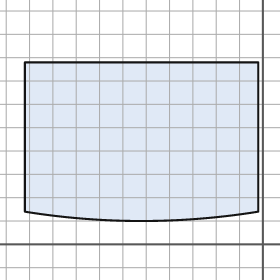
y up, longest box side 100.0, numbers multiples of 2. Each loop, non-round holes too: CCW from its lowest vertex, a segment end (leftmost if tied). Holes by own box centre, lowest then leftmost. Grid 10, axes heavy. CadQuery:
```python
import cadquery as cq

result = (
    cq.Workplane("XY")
    .moveTo(-102.0, 14.0)
    .threePointArc((-52.0, 10.0), (-2.0, 14.0))
    .lineTo(-2.0, 78.0)
    .lineTo(-102.0, 78.0)
    .close()
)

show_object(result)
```